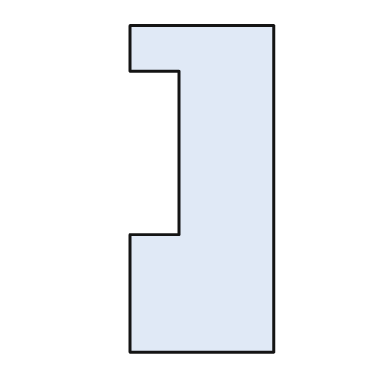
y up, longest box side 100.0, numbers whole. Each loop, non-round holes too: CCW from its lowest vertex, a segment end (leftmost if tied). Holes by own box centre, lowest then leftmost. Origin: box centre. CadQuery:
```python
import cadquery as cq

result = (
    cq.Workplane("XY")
    .moveTo(-22.0, -50.0)
    .lineTo(22.0, -50.0)
    .lineTo(22.0, 50.0)
    .lineTo(-22.0, 50.0)
    .lineTo(-22.0, 36.0)
    .lineTo(-7.0, 36.0)
    .lineTo(-7.0, -14.0)
    .lineTo(-22.0, -14.0)
    .close()
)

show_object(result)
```